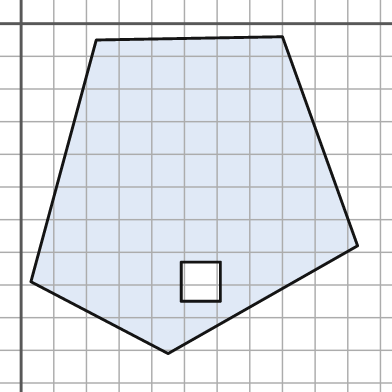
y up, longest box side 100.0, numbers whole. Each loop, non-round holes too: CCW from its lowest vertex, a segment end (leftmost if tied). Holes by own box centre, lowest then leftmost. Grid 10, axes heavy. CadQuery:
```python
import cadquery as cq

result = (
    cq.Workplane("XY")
    .moveTo(45.0, -101.0)
    .lineTo(103.0, -68.0)
    .lineTo(80.0, -4.0)
    .lineTo(23.0, -5.0)
    .lineTo(3.0, -79.0)
    .close()
    .moveTo(49.0, -85.0)
    .lineTo(61.0, -85.0)
    .lineTo(61.0, -73.0)
    .lineTo(49.0, -73.0)
    .close()
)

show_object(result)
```